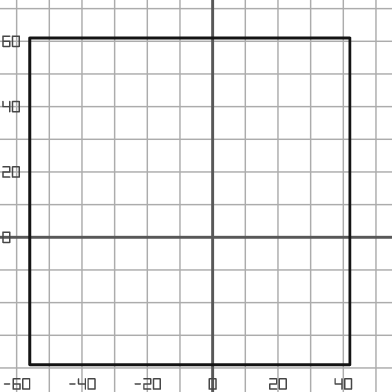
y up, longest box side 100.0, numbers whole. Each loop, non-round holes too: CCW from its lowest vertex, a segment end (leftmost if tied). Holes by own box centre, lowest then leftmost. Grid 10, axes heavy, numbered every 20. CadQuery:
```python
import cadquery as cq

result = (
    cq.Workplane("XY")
    .moveTo(-56.0, -39.0)
    .lineTo(42.0, -39.0)
    .lineTo(42.0, 61.0)
    .lineTo(-56.0, 61.0)
    .close()
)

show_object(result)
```